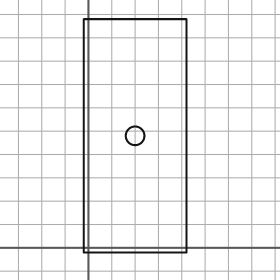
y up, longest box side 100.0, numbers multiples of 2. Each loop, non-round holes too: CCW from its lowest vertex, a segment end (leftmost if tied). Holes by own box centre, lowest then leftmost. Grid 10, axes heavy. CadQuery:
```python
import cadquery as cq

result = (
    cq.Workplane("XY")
    .moveTo(-2.0, -2.0)
    .lineTo(42.0, -2.0)
    .lineTo(42.0, 98.0)
    .lineTo(-2.0, 98.0)
    .close()
    .moveTo(20.0, 48.0)
    .circle(4.0)
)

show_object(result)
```